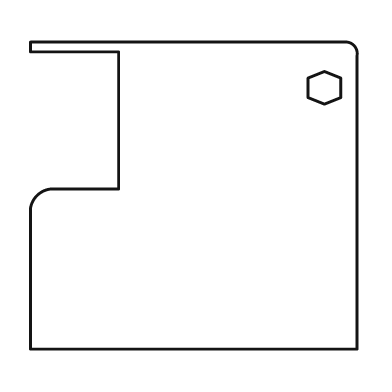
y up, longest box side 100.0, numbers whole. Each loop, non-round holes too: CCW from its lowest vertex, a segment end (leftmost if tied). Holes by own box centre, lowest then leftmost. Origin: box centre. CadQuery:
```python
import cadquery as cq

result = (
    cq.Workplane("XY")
    .moveTo(-50.0, -47.0)
    .lineTo(50.0, -47.0)
    .lineTo(50.0, 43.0)
    .threePointArc((49.0, 46.0), (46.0, 47.0))
    .lineTo(-50.0, 47.0)
    .lineTo(-50.0, 44.0)
    .lineTo(-23.0, 44.0)
    .lineTo(-23.0, 2.0)
    .lineTo(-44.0, 2.0)
    .threePointArc((-48.0, 0.0), (-50.0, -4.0))
    .close()
    .moveTo(40.0, 28.0)
    .lineTo(45.0, 30.0)
    .lineTo(45.0, 36.0)
    .lineTo(40.0, 38.0)
    .lineTo(35.0, 36.0)
    .lineTo(35.0, 30.0)
    .close()
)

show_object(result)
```